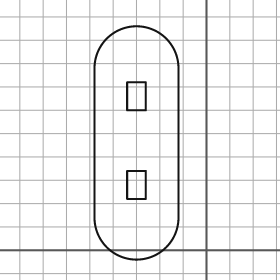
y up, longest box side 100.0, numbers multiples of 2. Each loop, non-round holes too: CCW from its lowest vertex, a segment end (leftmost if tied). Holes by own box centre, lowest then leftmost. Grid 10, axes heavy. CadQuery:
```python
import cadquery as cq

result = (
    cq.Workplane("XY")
    .moveTo(-48.0, 14.0)
    .threePointArc((-30.0, -4.0), (-12.0, 14.0))
    .lineTo(-12.0, 78.0)
    .threePointArc((-30.0, 96.0), (-48.0, 78.0))
    .close()
    .moveTo(-34.0, 22.0)
    .lineTo(-26.0, 22.0)
    .lineTo(-26.0, 34.0)
    .lineTo(-34.0, 34.0)
    .close()
    .moveTo(-34.0, 60.0)
    .lineTo(-26.0, 60.0)
    .lineTo(-26.0, 72.0)
    .lineTo(-34.0, 72.0)
    .close()
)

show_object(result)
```